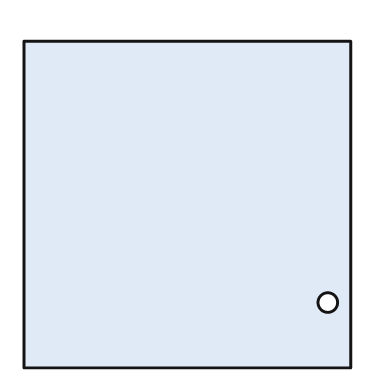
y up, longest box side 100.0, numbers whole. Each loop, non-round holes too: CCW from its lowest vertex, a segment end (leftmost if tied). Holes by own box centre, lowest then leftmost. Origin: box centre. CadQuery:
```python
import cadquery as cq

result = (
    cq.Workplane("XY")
    .moveTo(-50.0, -50.0)
    .lineTo(50.0, -50.0)
    .lineTo(50.0, 50.0)
    .lineTo(-50.0, 50.0)
    .close()
    .moveTo(43.0, -30.0)
    .circle(3.0)
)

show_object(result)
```